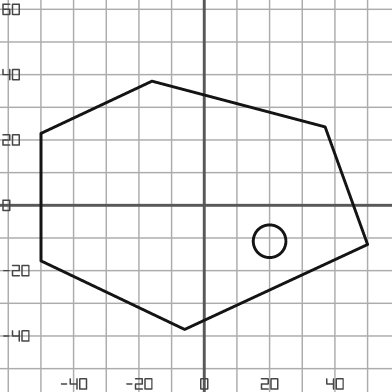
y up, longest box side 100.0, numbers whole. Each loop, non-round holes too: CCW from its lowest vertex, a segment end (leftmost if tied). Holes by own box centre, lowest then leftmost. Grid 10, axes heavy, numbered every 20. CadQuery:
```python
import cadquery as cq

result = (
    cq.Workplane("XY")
    .moveTo(-6.0, -38.0)
    .lineTo(50.0, -12.0)
    .lineTo(37.0, 24.0)
    .lineTo(-16.0, 38.0)
    .lineTo(-50.0, 22.0)
    .lineTo(-50.0, -17.0)
    .close()
    .moveTo(20.0, -11.0)
    .circle(5.0)
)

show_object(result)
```